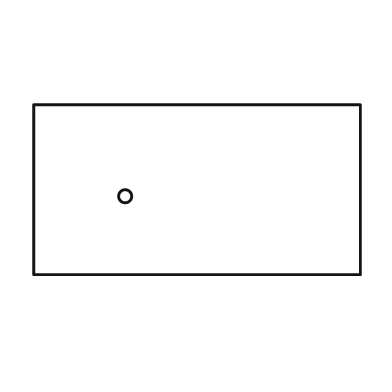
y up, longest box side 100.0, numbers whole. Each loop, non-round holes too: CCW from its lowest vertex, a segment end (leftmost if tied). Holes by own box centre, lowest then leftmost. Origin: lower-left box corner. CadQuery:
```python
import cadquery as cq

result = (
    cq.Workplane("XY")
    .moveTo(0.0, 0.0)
    .lineTo(100.0, 0.0)
    .lineTo(100.0, 52.0)
    .lineTo(0.0, 52.0)
    .close()
    .moveTo(28.0, 24.0)
    .circle(2.0)
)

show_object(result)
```